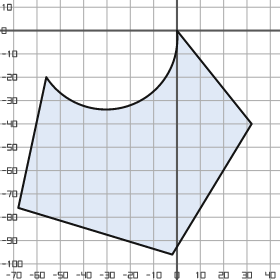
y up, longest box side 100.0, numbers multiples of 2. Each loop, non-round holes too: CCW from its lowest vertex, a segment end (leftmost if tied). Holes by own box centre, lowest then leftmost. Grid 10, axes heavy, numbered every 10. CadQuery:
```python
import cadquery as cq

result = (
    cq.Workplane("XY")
    .moveTo(-2.0, -96.0)
    .lineTo(32.0, -40.0)
    .lineTo(0.0, 0.0)
    .threePointArc((-20.0, -32.0), (-56.0, -20.0))
    .lineTo(-68.0, -76.0)
    .close()
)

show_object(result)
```